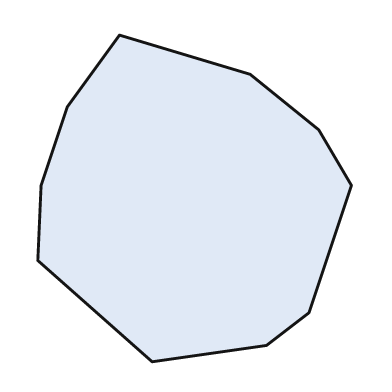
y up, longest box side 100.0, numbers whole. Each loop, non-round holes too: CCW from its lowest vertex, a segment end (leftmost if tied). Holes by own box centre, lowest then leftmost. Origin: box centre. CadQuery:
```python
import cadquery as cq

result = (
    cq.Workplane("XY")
    .moveTo(-13.0, -50.0)
    .lineTo(22.0, -45.0)
    .lineTo(35.0, -35.0)
    .lineTo(48.0, 4.0)
    .lineTo(38.0, 21.0)
    .lineTo(17.0, 38.0)
    .lineTo(-23.0, 50.0)
    .lineTo(-39.0, 28.0)
    .lineTo(-47.0, 4.0)
    .lineTo(-48.0, -19.0)
    .close()
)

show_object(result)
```